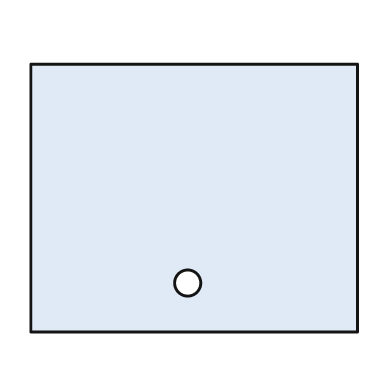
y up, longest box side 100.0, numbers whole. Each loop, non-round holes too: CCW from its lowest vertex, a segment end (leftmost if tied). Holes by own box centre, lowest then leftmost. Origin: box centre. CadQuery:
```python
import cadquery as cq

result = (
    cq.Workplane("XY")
    .moveTo(-50.0, -41.0)
    .lineTo(50.0, -41.0)
    .lineTo(50.0, 41.0)
    .lineTo(-50.0, 41.0)
    .close()
    .moveTo(-2.0, -26.0)
    .circle(4.0)
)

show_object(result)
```